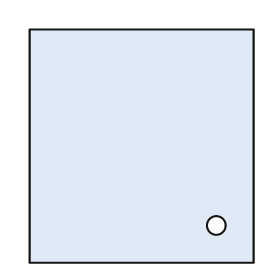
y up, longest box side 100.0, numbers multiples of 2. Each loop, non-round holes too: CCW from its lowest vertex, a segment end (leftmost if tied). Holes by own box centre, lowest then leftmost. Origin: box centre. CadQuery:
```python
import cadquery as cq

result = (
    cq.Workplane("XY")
    .moveTo(-48.0, -50.0)
    .lineTo(48.0, -50.0)
    .lineTo(48.0, 50.0)
    .lineTo(-48.0, 50.0)
    .close()
    .moveTo(32.0, -34.0)
    .circle(4.0)
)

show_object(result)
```